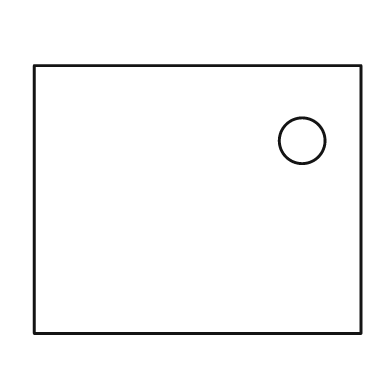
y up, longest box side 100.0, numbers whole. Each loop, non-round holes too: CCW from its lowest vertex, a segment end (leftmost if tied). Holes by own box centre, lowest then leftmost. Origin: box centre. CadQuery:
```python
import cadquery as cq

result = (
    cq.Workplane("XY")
    .moveTo(-50.0, -41.0)
    .lineTo(50.0, -41.0)
    .lineTo(50.0, 41.0)
    .lineTo(-50.0, 41.0)
    .close()
    .moveTo(32.0, 18.0)
    .circle(7.0)
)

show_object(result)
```